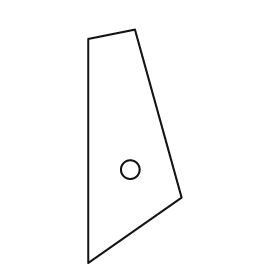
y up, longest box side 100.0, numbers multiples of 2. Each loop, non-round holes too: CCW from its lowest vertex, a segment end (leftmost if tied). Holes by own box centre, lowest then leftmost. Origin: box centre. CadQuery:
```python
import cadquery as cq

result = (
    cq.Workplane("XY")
    .moveTo(-20.0, -50.0)
    .lineTo(20.0, -22.0)
    .lineTo(0.0, 50.0)
    .lineTo(-20.0, 46.0)
    .close()
    .moveTo(-2.0, -10.0)
    .circle(4.0)
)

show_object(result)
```